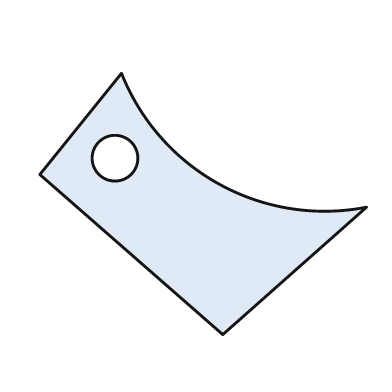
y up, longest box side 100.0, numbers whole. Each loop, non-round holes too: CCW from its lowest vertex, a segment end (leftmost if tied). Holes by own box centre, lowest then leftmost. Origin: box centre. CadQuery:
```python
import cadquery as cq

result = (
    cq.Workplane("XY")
    .moveTo(6.0, -40.0)
    .lineTo(50.0, -1.0)
    .threePointArc((5.0, 6.0), (-25.0, 40.0))
    .lineTo(-50.0, 9.0)
    .close()
    .moveTo(-27.0, 14.0)
    .circle(7.0)
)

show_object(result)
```